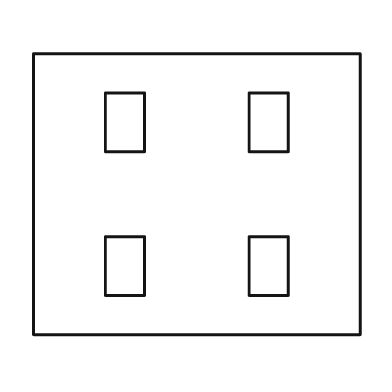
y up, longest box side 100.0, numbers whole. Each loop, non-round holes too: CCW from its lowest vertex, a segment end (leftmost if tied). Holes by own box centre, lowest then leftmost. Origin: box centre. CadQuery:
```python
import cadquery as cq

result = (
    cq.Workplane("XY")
    .moveTo(-50.0, -43.0)
    .lineTo(50.0, -43.0)
    .lineTo(50.0, 43.0)
    .lineTo(-50.0, 43.0)
    .close()
    .moveTo(-28.0, -31.0)
    .lineTo(-16.0, -31.0)
    .lineTo(-16.0, -13.0)
    .lineTo(-28.0, -13.0)
    .close()
    .moveTo(16.0, -31.0)
    .lineTo(28.0, -31.0)
    .lineTo(28.0, -13.0)
    .lineTo(16.0, -13.0)
    .close()
    .moveTo(-28.0, 13.0)
    .lineTo(-16.0, 13.0)
    .lineTo(-16.0, 31.0)
    .lineTo(-28.0, 31.0)
    .close()
    .moveTo(16.0, 13.0)
    .lineTo(28.0, 13.0)
    .lineTo(28.0, 31.0)
    .lineTo(16.0, 31.0)
    .close()
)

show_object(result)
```